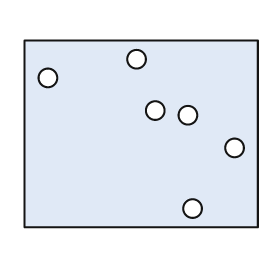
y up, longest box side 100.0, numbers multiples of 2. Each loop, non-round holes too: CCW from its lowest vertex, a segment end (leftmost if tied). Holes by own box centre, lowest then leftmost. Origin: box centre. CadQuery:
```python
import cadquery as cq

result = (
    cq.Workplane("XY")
    .moveTo(-50.0, -40.0)
    .lineTo(50.0, -40.0)
    .lineTo(50.0, 40.0)
    .lineTo(-50.0, 40.0)
    .close()
    .moveTo(22.0, -32.0)
    .circle(4.0)
    .moveTo(40.0, -6.0)
    .circle(4.0)
    .moveTo(20.0, 8.0)
    .circle(4.0)
    .moveTo(6.0, 10.0)
    .circle(4.0)
    .moveTo(-40.0, 24.0)
    .circle(4.0)
    .moveTo(-2.0, 32.0)
    .circle(4.0)
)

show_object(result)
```